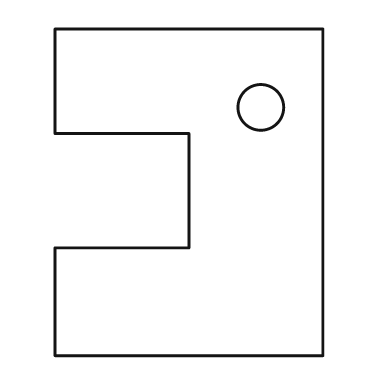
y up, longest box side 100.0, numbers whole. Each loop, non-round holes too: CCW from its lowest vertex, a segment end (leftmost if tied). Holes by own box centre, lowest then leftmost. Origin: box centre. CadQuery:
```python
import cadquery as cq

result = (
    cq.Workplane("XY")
    .moveTo(-41.0, -50.0)
    .lineTo(41.0, -50.0)
    .lineTo(41.0, 50.0)
    .lineTo(-41.0, 50.0)
    .lineTo(-41.0, 18.0)
    .lineTo(0.0, 18.0)
    .lineTo(0.0, -17.0)
    .lineTo(-41.0, -17.0)
    .close()
    .moveTo(22.0, 26.0)
    .circle(7.0)
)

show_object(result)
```